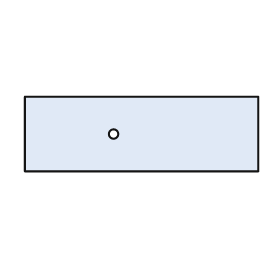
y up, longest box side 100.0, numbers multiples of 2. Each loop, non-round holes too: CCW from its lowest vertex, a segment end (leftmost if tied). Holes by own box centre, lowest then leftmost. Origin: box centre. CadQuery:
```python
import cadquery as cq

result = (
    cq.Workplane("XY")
    .moveTo(-50.0, -16.0)
    .lineTo(50.0, -16.0)
    .lineTo(50.0, 16.0)
    .lineTo(-50.0, 16.0)
    .close()
    .moveTo(-12.0, 0.0)
    .circle(2.0)
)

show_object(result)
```